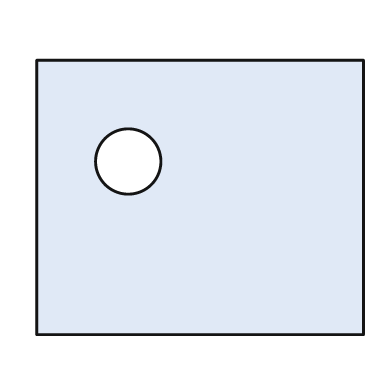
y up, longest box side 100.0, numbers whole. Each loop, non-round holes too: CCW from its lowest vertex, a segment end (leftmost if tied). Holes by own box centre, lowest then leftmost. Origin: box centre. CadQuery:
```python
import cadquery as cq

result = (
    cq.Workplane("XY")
    .moveTo(-50.0, -42.0)
    .lineTo(50.0, -42.0)
    .lineTo(50.0, 42.0)
    .lineTo(-50.0, 42.0)
    .close()
    .moveTo(-22.0, 11.0)
    .circle(10.0)
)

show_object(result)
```